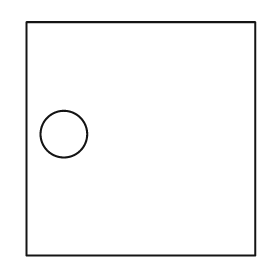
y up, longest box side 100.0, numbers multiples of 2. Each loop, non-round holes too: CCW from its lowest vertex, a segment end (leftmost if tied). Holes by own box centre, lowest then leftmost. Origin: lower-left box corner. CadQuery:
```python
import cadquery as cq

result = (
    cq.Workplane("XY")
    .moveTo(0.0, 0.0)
    .lineTo(98.0, 0.0)
    .lineTo(98.0, 100.0)
    .lineTo(0.0, 100.0)
    .close()
    .moveTo(16.0, 52.0)
    .circle(10.0)
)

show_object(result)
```